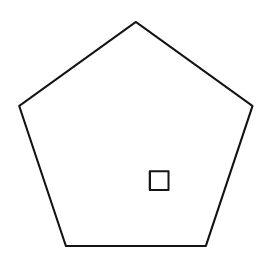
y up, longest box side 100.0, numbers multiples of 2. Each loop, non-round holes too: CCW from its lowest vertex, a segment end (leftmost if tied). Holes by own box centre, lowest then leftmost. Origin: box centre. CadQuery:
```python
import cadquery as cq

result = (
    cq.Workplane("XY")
    .moveTo(-30.0, -48.0)
    .lineTo(30.0, -48.0)
    .lineTo(50.0, 12.0)
    .lineTo(0.0, 48.0)
    .lineTo(-50.0, 12.0)
    .close()
    .moveTo(6.0, -24.0)
    .lineTo(14.0, -24.0)
    .lineTo(14.0, -16.0)
    .lineTo(6.0, -16.0)
    .close()
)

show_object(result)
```